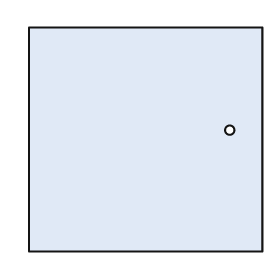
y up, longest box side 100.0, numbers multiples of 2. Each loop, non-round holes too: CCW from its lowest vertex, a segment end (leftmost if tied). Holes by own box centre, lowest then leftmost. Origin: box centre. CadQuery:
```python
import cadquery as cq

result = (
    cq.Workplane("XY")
    .moveTo(-50.0, -48.0)
    .lineTo(50.0, -48.0)
    .lineTo(50.0, 48.0)
    .lineTo(-50.0, 48.0)
    .close()
    .moveTo(36.0, 4.0)
    .circle(2.0)
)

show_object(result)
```